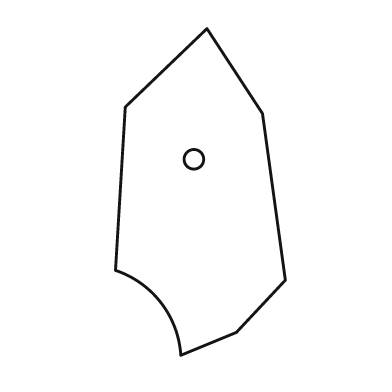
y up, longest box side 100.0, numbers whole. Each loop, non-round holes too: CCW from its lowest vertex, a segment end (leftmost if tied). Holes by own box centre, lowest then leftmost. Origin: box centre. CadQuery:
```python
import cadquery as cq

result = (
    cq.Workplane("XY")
    .moveTo(-6.0, -50.0)
    .lineTo(11.0, -43.0)
    .lineTo(26.0, -27.0)
    .lineTo(19.0, 24.0)
    .lineTo(2.0, 50.0)
    .lineTo(-23.0, 26.0)
    .lineTo(-26.0, -24.0)
    .threePointArc((-12.0, -34.0), (-6.0, -50.0))
    .close()
    .moveTo(-2.0, 10.0)
    .circle(3.0)
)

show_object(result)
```